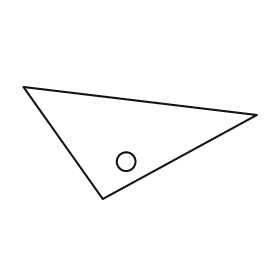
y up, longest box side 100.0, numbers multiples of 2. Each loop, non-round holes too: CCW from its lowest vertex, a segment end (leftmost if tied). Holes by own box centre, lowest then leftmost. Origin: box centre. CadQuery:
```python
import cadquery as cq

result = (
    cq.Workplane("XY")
    .moveTo(-16.0, -24.0)
    .lineTo(50.0, 12.0)
    .lineTo(-50.0, 24.0)
    .close()
    .moveTo(-6.0, -8.0)
    .circle(4.0)
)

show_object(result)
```